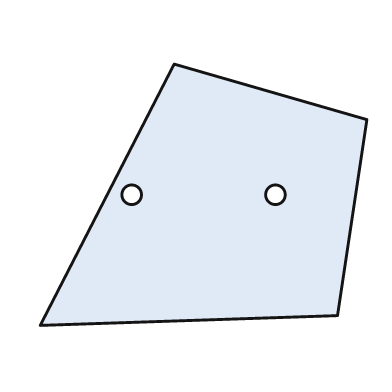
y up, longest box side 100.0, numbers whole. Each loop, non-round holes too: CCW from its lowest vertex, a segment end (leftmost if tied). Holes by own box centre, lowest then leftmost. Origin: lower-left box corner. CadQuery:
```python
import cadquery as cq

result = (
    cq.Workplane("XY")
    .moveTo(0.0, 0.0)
    .lineTo(91.0, 3.0)
    .lineTo(100.0, 63.0)
    .lineTo(41.0, 80.0)
    .close()
    .moveTo(28.0, 40.0)
    .circle(3.0)
    .moveTo(72.0, 40.0)
    .circle(3.0)
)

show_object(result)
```